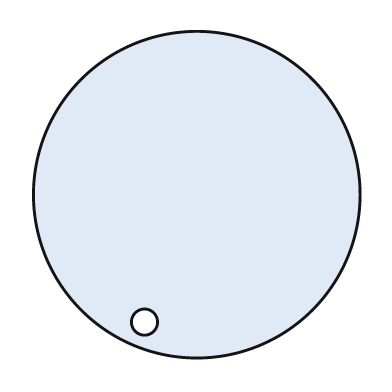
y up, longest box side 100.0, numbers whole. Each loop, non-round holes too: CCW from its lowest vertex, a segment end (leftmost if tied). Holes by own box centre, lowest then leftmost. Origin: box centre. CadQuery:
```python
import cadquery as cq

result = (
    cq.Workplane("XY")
    .moveTo(0.0, 0.0)
    .circle(50.0)
    .moveTo(-16.0, -39.0)
    .circle(4.0)
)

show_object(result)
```